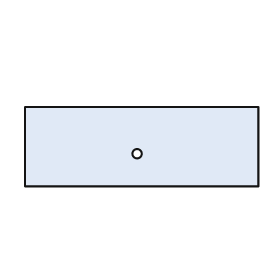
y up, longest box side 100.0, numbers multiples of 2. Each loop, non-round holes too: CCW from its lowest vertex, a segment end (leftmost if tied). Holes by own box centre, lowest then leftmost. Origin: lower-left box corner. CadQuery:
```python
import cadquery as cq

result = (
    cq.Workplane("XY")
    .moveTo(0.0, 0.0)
    .lineTo(100.0, 0.0)
    .lineTo(100.0, 34.0)
    .lineTo(0.0, 34.0)
    .close()
    .moveTo(48.0, 14.0)
    .circle(2.0)
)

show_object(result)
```